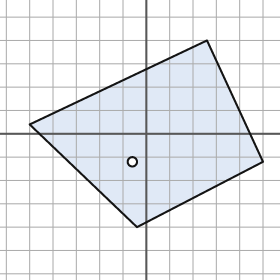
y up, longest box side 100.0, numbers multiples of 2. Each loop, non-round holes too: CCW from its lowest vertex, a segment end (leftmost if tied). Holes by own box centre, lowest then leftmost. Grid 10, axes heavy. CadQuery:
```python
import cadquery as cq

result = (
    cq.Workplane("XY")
    .moveTo(-4.0, -40.0)
    .lineTo(50.0, -12.0)
    .lineTo(26.0, 40.0)
    .lineTo(-50.0, 4.0)
    .close()
    .moveTo(-6.0, -12.0)
    .circle(2.0)
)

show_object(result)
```